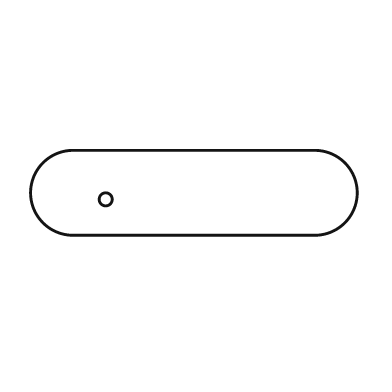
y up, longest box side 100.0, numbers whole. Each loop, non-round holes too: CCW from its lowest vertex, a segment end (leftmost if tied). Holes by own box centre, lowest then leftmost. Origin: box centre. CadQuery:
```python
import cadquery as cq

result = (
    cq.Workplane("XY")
    .moveTo(-37.0, -13.0)
    .lineTo(37.0, -13.0)
    .threePointArc((50.0, 0.0), (37.0, 13.0))
    .lineTo(-37.0, 13.0)
    .threePointArc((-50.0, 0.0), (-37.0, -13.0))
    .close()
    .moveTo(-27.0, -2.0)
    .circle(2.0)
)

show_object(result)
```